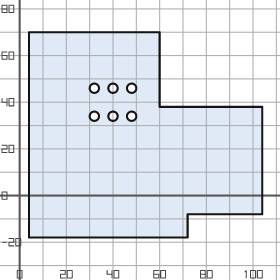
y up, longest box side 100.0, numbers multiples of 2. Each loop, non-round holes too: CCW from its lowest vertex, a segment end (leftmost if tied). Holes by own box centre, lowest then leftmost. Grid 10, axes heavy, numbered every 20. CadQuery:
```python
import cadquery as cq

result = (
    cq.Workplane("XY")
    .moveTo(4.0, -18.0)
    .lineTo(72.0, -18.0)
    .lineTo(72.0, -8.0)
    .lineTo(104.0, -8.0)
    .lineTo(104.0, 38.0)
    .lineTo(60.0, 38.0)
    .lineTo(60.0, 70.0)
    .lineTo(4.0, 70.0)
    .close()
    .moveTo(32.0, 34.0)
    .circle(2.0)
    .moveTo(40.0, 34.0)
    .circle(2.0)
    .moveTo(48.0, 34.0)
    .circle(2.0)
    .moveTo(32.0, 46.0)
    .circle(2.0)
    .moveTo(40.0, 46.0)
    .circle(2.0)
    .moveTo(48.0, 46.0)
    .circle(2.0)
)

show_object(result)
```